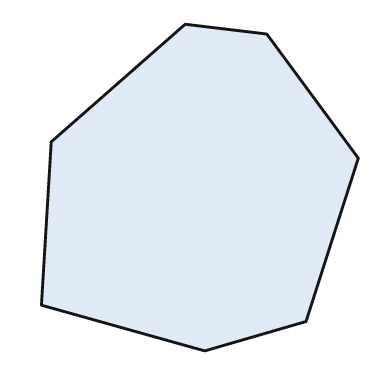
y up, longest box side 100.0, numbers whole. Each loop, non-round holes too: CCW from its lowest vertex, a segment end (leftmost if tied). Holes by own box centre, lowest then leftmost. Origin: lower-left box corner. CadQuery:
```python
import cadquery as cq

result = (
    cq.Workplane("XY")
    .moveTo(50.0, 0.0)
    .lineTo(81.0, 9.0)
    .lineTo(97.0, 59.0)
    .lineTo(69.0, 97.0)
    .lineTo(44.0, 100.0)
    .lineTo(3.0, 64.0)
    .lineTo(0.0, 14.0)
    .close()
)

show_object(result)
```